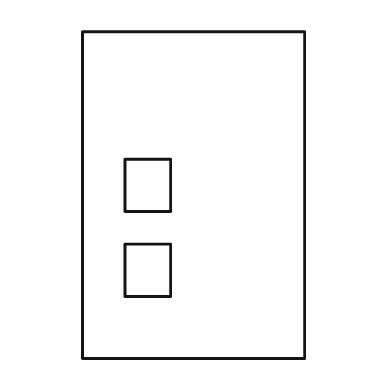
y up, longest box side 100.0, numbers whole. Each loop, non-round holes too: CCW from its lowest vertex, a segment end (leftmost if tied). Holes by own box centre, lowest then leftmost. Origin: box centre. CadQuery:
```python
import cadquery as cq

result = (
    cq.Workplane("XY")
    .moveTo(-34.0, -50.0)
    .lineTo(34.0, -50.0)
    .lineTo(34.0, 50.0)
    .lineTo(-34.0, 50.0)
    .close()
    .moveTo(-21.0, -31.0)
    .lineTo(-7.0, -31.0)
    .lineTo(-7.0, -15.0)
    .lineTo(-21.0, -15.0)
    .close()
    .moveTo(-21.0, -5.0)
    .lineTo(-7.0, -5.0)
    .lineTo(-7.0, 11.0)
    .lineTo(-21.0, 11.0)
    .close()
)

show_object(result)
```